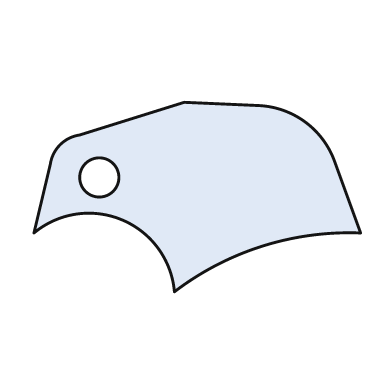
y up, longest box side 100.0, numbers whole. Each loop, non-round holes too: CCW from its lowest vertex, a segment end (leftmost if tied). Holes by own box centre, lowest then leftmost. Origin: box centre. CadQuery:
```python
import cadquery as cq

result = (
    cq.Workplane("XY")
    .moveTo(-7.0, -29.0)
    .threePointArc((20.0, -15.0), (50.0, -11.0))
    .lineTo(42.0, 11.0)
    .threePointArc((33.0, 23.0), (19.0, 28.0))
    .lineTo(-4.0, 29.0)
    .lineTo(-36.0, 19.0)
    .threePointArc((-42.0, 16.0), (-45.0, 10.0))
    .lineTo(-50.0, -11.0)
    .threePointArc((-23.0, -7.0), (-7.0, -29.0))
    .close()
    .moveTo(-30.0, 6.0)
    .circle(6.0)
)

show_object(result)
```